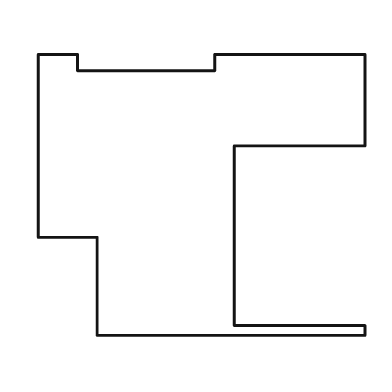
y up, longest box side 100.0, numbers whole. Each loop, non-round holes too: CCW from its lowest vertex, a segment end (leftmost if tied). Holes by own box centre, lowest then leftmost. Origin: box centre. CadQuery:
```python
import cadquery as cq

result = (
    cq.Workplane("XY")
    .moveTo(-32.0, -43.0)
    .lineTo(50.0, -43.0)
    .lineTo(50.0, -40.0)
    .lineTo(10.0, -40.0)
    .lineTo(10.0, 15.0)
    .lineTo(50.0, 15.0)
    .lineTo(50.0, 43.0)
    .lineTo(4.0, 43.0)
    .lineTo(4.0, 38.0)
    .lineTo(-38.0, 38.0)
    .lineTo(-38.0, 43.0)
    .lineTo(-50.0, 43.0)
    .lineTo(-50.0, -13.0)
    .lineTo(-32.0, -13.0)
    .close()
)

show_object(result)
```